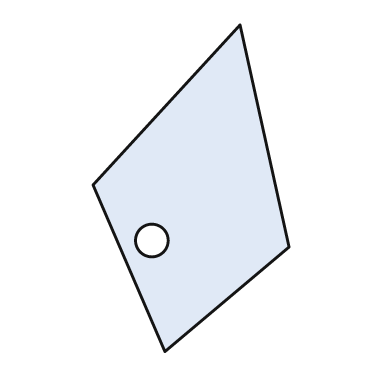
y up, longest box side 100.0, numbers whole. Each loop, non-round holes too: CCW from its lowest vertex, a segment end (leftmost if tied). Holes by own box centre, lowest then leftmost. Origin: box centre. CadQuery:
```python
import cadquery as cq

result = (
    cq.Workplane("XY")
    .moveTo(-8.0, -50.0)
    .lineTo(30.0, -18.0)
    .lineTo(15.0, 50.0)
    .lineTo(-30.0, 1.0)
    .close()
    .moveTo(-12.0, -16.0)
    .circle(5.0)
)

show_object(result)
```